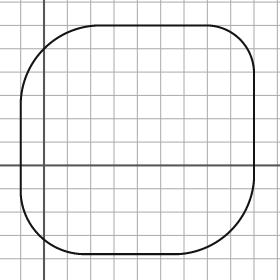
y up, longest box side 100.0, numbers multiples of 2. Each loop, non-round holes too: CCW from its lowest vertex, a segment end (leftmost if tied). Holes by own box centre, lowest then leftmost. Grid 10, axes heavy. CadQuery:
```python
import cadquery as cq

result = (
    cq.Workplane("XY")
    .moveTo(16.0, -38.0)
    .lineTo(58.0, -38.0)
    .threePointArc((80.0, -28.0), (90.0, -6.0))
    .lineTo(90.0, 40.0)
    .threePointArc((84.0, 54.0), (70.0, 60.0))
    .lineTo(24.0, 60.0)
    .threePointArc((0.0, 50.0), (-10.0, 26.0))
    .lineTo(-10.0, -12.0)
    .threePointArc((-2.0, -30.0), (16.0, -38.0))
    .close()
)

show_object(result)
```